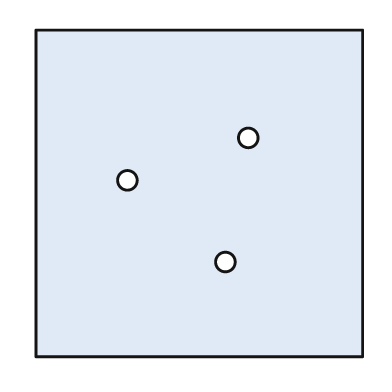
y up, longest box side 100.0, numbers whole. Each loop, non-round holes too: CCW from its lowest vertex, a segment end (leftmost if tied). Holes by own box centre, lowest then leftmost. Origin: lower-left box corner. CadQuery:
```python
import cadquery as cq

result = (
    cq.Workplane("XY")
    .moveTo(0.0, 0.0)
    .lineTo(100.0, 0.0)
    .lineTo(100.0, 100.0)
    .lineTo(0.0, 100.0)
    .close()
    .moveTo(58.0, 29.0)
    .circle(3.0)
    .moveTo(28.0, 54.0)
    .circle(3.0)
    .moveTo(65.0, 67.0)
    .circle(3.0)
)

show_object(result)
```